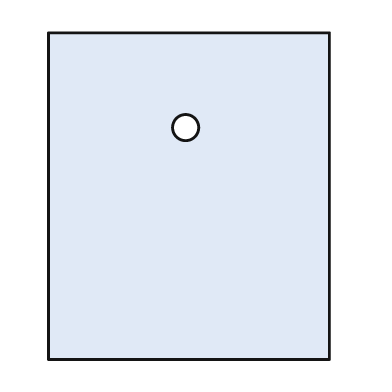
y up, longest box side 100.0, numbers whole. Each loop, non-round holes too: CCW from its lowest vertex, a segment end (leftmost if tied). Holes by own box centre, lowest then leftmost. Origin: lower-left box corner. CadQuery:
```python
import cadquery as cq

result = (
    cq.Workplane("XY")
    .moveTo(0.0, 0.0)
    .lineTo(86.0, 0.0)
    .lineTo(86.0, 100.0)
    .lineTo(0.0, 100.0)
    .close()
    .moveTo(42.0, 71.0)
    .circle(4.0)
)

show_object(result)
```